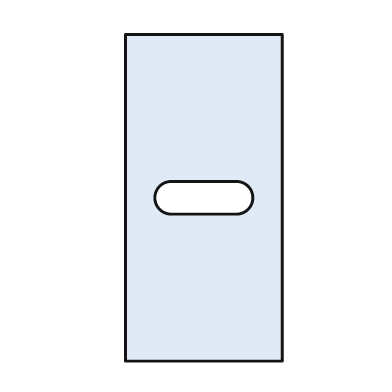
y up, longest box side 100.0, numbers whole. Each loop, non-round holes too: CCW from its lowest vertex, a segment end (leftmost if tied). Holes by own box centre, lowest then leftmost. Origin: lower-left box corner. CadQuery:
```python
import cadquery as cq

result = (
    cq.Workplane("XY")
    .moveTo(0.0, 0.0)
    .lineTo(48.0, 0.0)
    .lineTo(48.0, 100.0)
    .lineTo(0.0, 100.0)
    .close()
    .moveTo(14.0, 45.0)
    .lineTo(34.0, 45.0)
    .threePointArc((39.0, 50.0), (34.0, 55.0))
    .lineTo(14.0, 55.0)
    .threePointArc((9.0, 50.0), (14.0, 45.0))
    .close()
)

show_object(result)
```